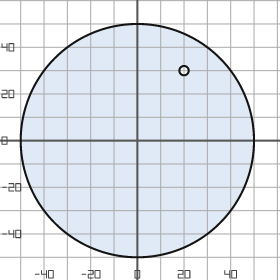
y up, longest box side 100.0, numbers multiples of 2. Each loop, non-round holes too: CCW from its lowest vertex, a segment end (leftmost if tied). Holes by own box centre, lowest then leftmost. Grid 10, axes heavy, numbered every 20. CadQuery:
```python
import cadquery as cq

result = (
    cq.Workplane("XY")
    .moveTo(0.0, 0.0)
    .circle(50.0)
    .moveTo(20.0, 30.0)
    .circle(2.0)
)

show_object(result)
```